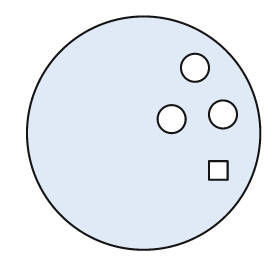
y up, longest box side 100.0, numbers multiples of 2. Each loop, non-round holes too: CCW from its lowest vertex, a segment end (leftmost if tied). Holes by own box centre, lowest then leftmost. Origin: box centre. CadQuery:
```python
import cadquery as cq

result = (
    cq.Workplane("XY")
    .moveTo(0.0, 0.0)
    .circle(50.0)
    .moveTo(28.0, -20.0)
    .lineTo(36.0, -20.0)
    .lineTo(36.0, -12.0)
    .lineTo(28.0, -12.0)
    .close()
    .moveTo(12.0, 6.0)
    .circle(6.0)
    .moveTo(34.0, 8.0)
    .circle(6.0)
    .moveTo(22.0, 28.0)
    .circle(6.0)
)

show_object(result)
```